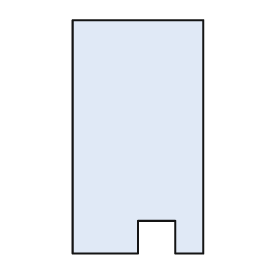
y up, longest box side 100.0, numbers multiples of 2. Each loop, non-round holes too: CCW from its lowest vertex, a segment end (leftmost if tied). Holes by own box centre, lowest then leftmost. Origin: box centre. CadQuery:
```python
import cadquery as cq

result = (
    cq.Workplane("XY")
    .moveTo(-28.0, -50.0)
    .lineTo(0.0, -50.0)
    .lineTo(0.0, -36.0)
    .lineTo(16.0, -36.0)
    .lineTo(16.0, -50.0)
    .lineTo(28.0, -50.0)
    .lineTo(28.0, 50.0)
    .lineTo(-28.0, 50.0)
    .close()
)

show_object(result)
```